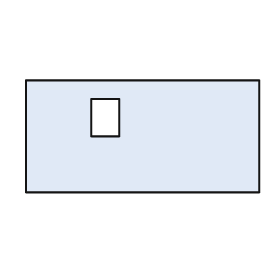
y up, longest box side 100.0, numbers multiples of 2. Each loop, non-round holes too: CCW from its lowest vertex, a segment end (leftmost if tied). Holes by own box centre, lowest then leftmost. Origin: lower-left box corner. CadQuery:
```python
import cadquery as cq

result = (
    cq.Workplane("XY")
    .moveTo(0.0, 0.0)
    .lineTo(100.0, 0.0)
    .lineTo(100.0, 48.0)
    .lineTo(0.0, 48.0)
    .close()
    .moveTo(28.0, 24.0)
    .lineTo(40.0, 24.0)
    .lineTo(40.0, 40.0)
    .lineTo(28.0, 40.0)
    .close()
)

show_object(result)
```